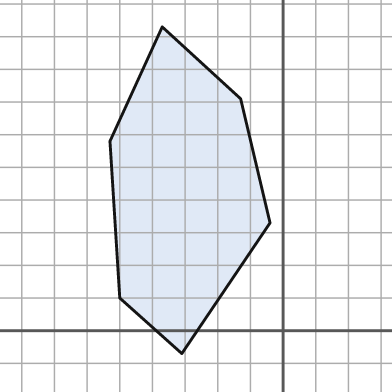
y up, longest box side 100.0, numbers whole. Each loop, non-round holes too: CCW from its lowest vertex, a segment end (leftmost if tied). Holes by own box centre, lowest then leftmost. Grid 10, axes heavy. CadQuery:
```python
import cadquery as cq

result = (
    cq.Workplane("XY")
    .moveTo(-31.0, -7.0)
    .lineTo(-4.0, 33.0)
    .lineTo(-13.0, 71.0)
    .lineTo(-37.0, 93.0)
    .lineTo(-53.0, 58.0)
    .lineTo(-50.0, 10.0)
    .close()
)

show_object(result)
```